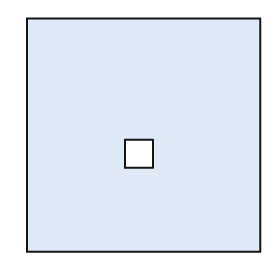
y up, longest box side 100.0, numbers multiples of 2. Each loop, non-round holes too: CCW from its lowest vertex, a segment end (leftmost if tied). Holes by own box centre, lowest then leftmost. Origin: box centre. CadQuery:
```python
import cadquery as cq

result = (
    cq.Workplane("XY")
    .moveTo(-50.0, -50.0)
    .lineTo(50.0, -50.0)
    .lineTo(50.0, 50.0)
    .lineTo(-50.0, 50.0)
    .close()
    .moveTo(-8.0, -14.0)
    .lineTo(4.0, -14.0)
    .lineTo(4.0, -2.0)
    .lineTo(-8.0, -2.0)
    .close()
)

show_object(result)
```